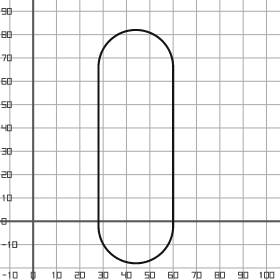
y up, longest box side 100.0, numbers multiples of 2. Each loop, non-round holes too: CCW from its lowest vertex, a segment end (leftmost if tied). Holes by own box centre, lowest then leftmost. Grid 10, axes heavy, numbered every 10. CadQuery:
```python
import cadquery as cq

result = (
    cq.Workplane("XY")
    .moveTo(28.0, -2.0)
    .threePointArc((44.0, -18.0), (60.0, -2.0))
    .lineTo(60.0, 66.0)
    .threePointArc((44.0, 82.0), (28.0, 66.0))
    .close()
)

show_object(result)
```